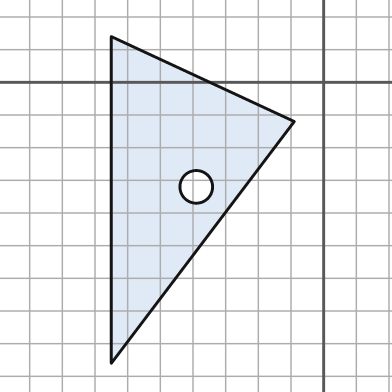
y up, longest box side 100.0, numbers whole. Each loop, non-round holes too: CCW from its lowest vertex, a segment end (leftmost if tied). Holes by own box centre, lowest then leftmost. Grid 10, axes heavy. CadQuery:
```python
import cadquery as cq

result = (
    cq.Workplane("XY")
    .moveTo(-65.0, -86.0)
    .lineTo(-9.0, -12.0)
    .lineTo(-65.0, 14.0)
    .close()
    .moveTo(-39.0, -32.0)
    .circle(5.0)
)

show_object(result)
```